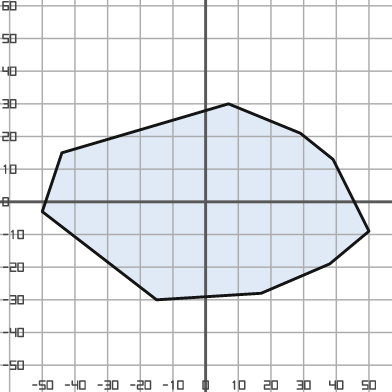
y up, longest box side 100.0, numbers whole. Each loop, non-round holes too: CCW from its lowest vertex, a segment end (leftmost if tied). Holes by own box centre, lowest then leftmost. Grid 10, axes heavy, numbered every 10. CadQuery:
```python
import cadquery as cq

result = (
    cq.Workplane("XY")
    .moveTo(-15.0, -30.0)
    .lineTo(17.0, -28.0)
    .lineTo(38.0, -19.0)
    .lineTo(50.0, -9.0)
    .lineTo(39.0, 13.0)
    .lineTo(29.0, 21.0)
    .lineTo(7.0, 30.0)
    .lineTo(-44.0, 15.0)
    .lineTo(-50.0, -3.0)
    .close()
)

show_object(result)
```